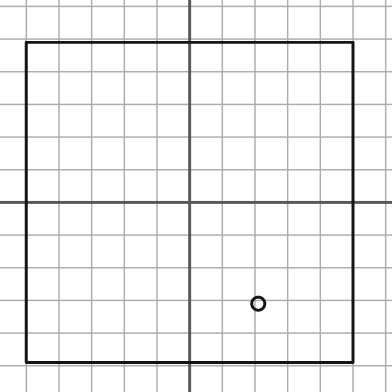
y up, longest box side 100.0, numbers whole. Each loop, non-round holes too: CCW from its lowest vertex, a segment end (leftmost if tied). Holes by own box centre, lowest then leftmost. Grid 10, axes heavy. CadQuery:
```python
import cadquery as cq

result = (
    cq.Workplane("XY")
    .moveTo(-50.0, -49.0)
    .lineTo(50.0, -49.0)
    .lineTo(50.0, 49.0)
    .lineTo(-50.0, 49.0)
    .close()
    .moveTo(21.0, -31.0)
    .circle(2.0)
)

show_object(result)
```